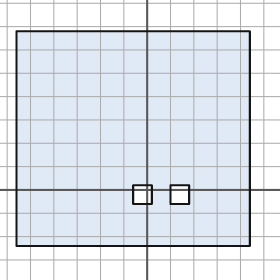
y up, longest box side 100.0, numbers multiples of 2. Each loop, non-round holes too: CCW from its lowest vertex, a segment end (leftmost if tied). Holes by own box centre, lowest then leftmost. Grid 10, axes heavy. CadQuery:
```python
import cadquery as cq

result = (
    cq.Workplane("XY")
    .moveTo(-56.0, -24.0)
    .lineTo(44.0, -24.0)
    .lineTo(44.0, 68.0)
    .lineTo(-56.0, 68.0)
    .close()
    .moveTo(-6.0, -6.0)
    .lineTo(2.0, -6.0)
    .lineTo(2.0, 2.0)
    .lineTo(-6.0, 2.0)
    .close()
    .moveTo(10.0, -6.0)
    .lineTo(18.0, -6.0)
    .lineTo(18.0, 2.0)
    .lineTo(10.0, 2.0)
    .close()
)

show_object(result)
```